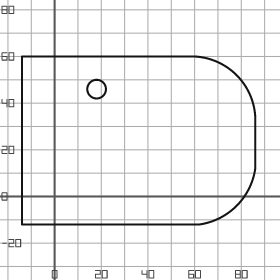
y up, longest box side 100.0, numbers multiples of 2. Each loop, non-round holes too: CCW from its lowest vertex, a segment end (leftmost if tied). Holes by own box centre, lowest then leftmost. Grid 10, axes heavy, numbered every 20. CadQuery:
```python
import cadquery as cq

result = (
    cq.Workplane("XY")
    .moveTo(-14.0, -12.0)
    .lineTo(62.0, -12.0)
    .threePointArc((78.0, -4.0), (86.0, 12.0))
    .lineTo(86.0, 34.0)
    .threePointArc((78.0, 52.0), (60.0, 60.0))
    .lineTo(-14.0, 60.0)
    .close()
    .moveTo(18.0, 46.0)
    .circle(4.0)
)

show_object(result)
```